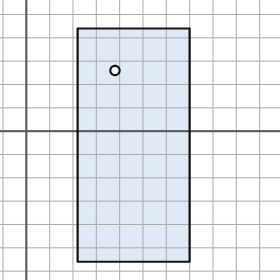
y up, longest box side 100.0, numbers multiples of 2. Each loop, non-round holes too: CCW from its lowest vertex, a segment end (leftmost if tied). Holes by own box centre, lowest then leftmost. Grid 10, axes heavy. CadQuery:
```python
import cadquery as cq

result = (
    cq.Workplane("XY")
    .moveTo(22.0, -56.0)
    .lineTo(70.0, -56.0)
    .lineTo(70.0, 44.0)
    .lineTo(22.0, 44.0)
    .close()
    .moveTo(38.0, 26.0)
    .circle(2.0)
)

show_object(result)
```